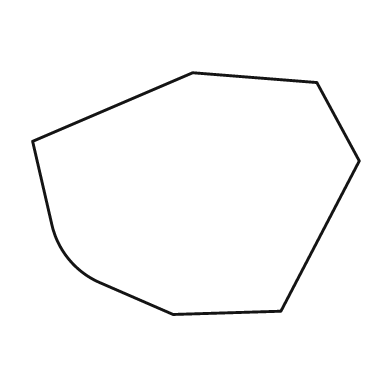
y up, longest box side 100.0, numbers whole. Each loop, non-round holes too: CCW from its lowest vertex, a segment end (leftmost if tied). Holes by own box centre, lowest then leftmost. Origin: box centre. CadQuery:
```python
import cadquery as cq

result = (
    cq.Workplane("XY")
    .moveTo(-7.0, -37.0)
    .lineTo(26.0, -36.0)
    .lineTo(50.0, 10.0)
    .lineTo(37.0, 34.0)
    .lineTo(-1.0, 37.0)
    .lineTo(-50.0, 16.0)
    .lineTo(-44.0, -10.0)
    .threePointArc((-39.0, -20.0), (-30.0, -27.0))
    .close()
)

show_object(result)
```